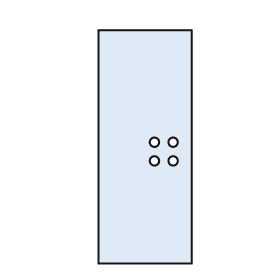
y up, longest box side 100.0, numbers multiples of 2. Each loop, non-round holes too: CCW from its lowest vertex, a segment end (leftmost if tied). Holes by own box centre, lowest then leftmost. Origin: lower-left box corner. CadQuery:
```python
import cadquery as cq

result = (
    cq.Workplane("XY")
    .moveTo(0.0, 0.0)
    .lineTo(40.0, 0.0)
    .lineTo(40.0, 100.0)
    .lineTo(0.0, 100.0)
    .close()
    .moveTo(24.0, 44.0)
    .circle(2.0)
    .moveTo(32.0, 44.0)
    .circle(2.0)
    .moveTo(24.0, 52.0)
    .circle(2.0)
    .moveTo(32.0, 52.0)
    .circle(2.0)
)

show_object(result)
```